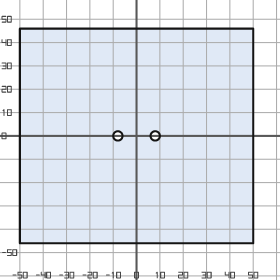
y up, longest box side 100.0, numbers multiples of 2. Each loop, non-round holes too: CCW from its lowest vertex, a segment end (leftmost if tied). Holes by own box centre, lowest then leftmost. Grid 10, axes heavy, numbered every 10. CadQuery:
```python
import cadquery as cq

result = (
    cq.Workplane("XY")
    .moveTo(-50.0, -46.0)
    .lineTo(50.0, -46.0)
    .lineTo(50.0, 46.0)
    .lineTo(-50.0, 46.0)
    .close()
    .moveTo(-8.0, 0.0)
    .circle(2.0)
    .moveTo(8.0, 0.0)
    .circle(2.0)
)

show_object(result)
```